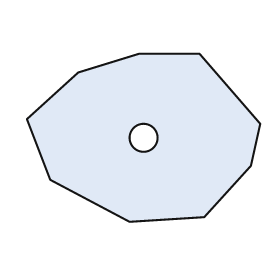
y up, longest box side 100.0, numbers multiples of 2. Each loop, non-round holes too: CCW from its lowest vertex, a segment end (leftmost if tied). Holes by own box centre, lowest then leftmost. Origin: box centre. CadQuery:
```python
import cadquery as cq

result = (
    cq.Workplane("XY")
    .moveTo(-6.0, -36.0)
    .lineTo(26.0, -34.0)
    .lineTo(46.0, -12.0)
    .lineTo(50.0, 6.0)
    .lineTo(24.0, 36.0)
    .lineTo(-2.0, 36.0)
    .lineTo(-28.0, 28.0)
    .lineTo(-50.0, 8.0)
    .lineTo(-40.0, -18.0)
    .close()
    .moveTo(0.0, 0.0)
    .circle(6.0)
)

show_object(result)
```